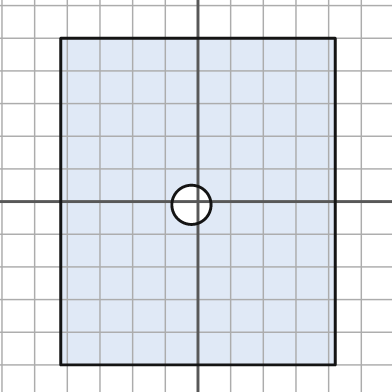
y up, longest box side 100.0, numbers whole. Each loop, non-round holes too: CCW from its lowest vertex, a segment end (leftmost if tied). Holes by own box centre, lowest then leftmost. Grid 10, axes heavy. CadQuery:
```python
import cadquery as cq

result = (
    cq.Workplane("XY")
    .moveTo(-42.0, -50.0)
    .lineTo(42.0, -50.0)
    .lineTo(42.0, 50.0)
    .lineTo(-42.0, 50.0)
    .close()
    .moveTo(-2.0, -1.0)
    .circle(6.0)
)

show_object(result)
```